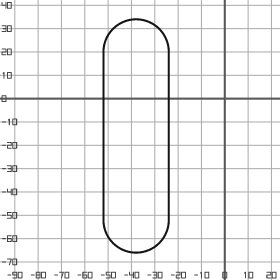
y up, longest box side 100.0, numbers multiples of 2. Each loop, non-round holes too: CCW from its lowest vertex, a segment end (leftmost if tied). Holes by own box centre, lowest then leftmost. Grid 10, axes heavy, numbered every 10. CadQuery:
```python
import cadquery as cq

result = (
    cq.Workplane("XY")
    .moveTo(-52.0, -52.0)
    .threePointArc((-38.0, -66.0), (-24.0, -52.0))
    .lineTo(-24.0, 20.0)
    .threePointArc((-38.0, 34.0), (-52.0, 20.0))
    .close()
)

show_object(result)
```